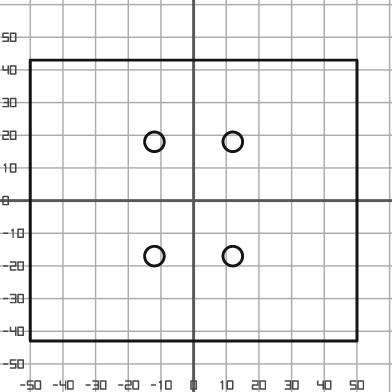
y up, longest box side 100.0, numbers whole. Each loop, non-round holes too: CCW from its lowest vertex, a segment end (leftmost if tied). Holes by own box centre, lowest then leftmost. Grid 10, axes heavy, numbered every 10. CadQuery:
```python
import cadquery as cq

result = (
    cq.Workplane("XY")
    .moveTo(-50.0, -43.0)
    .lineTo(50.0, -43.0)
    .lineTo(50.0, 43.0)
    .lineTo(-50.0, 43.0)
    .close()
    .moveTo(-12.0, -17.0)
    .circle(3.0)
    .moveTo(12.0, -17.0)
    .circle(3.0)
    .moveTo(-12.0, 18.0)
    .circle(3.0)
    .moveTo(12.0, 18.0)
    .circle(3.0)
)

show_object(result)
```